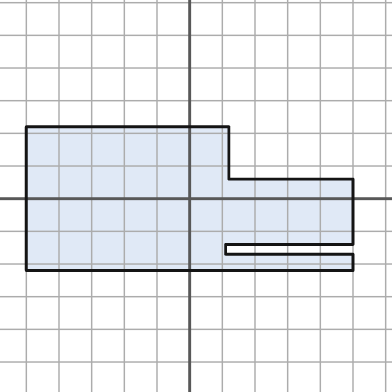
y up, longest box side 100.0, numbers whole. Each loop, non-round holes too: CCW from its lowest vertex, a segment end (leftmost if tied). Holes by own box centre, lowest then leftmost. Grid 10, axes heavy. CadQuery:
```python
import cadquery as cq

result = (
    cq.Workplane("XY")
    .moveTo(-50.0, -22.0)
    .lineTo(50.0, -22.0)
    .lineTo(50.0, -17.0)
    .lineTo(11.0, -17.0)
    .lineTo(11.0, -14.0)
    .lineTo(50.0, -14.0)
    .lineTo(50.0, 6.0)
    .lineTo(12.0, 6.0)
    .lineTo(12.0, 22.0)
    .lineTo(-50.0, 22.0)
    .close()
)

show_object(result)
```